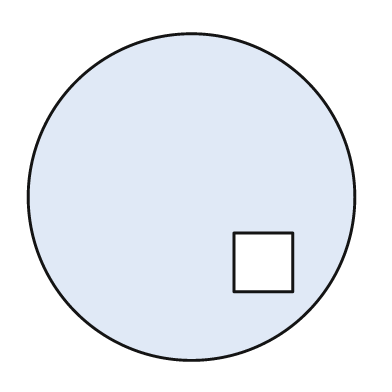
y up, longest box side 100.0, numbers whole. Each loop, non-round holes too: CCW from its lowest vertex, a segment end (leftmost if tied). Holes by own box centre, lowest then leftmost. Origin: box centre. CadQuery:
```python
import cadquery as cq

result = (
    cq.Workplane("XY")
    .moveTo(0.0, 0.0)
    .circle(50.0)
    .moveTo(13.0, -29.0)
    .lineTo(31.0, -29.0)
    .lineTo(31.0, -11.0)
    .lineTo(13.0, -11.0)
    .close()
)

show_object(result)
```